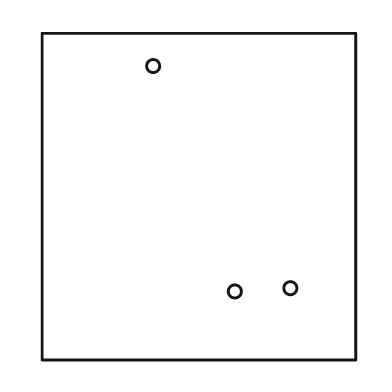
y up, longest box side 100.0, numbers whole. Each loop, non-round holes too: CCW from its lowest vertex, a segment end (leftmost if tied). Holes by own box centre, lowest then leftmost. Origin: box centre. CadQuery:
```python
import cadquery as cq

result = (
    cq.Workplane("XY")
    .moveTo(-48.0, -50.0)
    .lineTo(48.0, -50.0)
    .lineTo(48.0, 50.0)
    .lineTo(-48.0, 50.0)
    .close()
    .moveTo(11.0, -29.0)
    .circle(2.0)
    .moveTo(28.0, -28.0)
    .circle(2.0)
    .moveTo(-14.0, 40.0)
    .circle(2.0)
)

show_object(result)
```